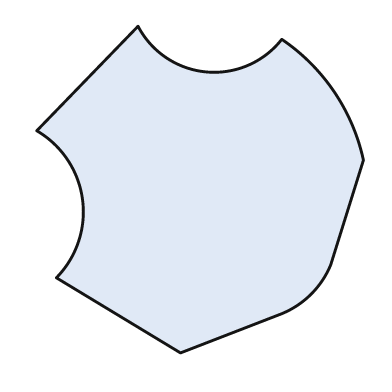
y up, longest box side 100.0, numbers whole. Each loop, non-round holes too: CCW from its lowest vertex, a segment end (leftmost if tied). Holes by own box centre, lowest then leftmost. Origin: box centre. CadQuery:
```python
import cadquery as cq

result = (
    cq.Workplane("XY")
    .moveTo(-6.0, -50.0)
    .lineTo(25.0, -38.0)
    .threePointArc((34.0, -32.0), (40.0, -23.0))
    .lineTo(50.0, 9.0)
    .threePointArc((41.0, 30.0), (25.0, 46.0))
    .threePointArc((2.0, 36.0), (-19.0, 50.0))
    .lineTo(-50.0, 18.0)
    .threePointArc((-36.0, -3.0), (-44.0, -27.0))
    .close()
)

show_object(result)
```